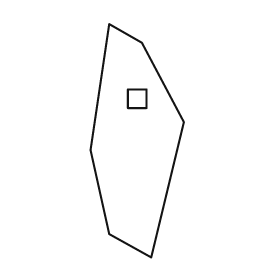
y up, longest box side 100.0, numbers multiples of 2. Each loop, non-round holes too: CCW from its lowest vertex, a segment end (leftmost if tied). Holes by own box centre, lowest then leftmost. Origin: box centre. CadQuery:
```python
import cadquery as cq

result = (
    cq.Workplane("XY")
    .moveTo(6.0, -50.0)
    .lineTo(20.0, 8.0)
    .lineTo(2.0, 42.0)
    .lineTo(-12.0, 50.0)
    .lineTo(-20.0, -4.0)
    .lineTo(-12.0, -40.0)
    .close()
    .moveTo(-4.0, 14.0)
    .lineTo(4.0, 14.0)
    .lineTo(4.0, 22.0)
    .lineTo(-4.0, 22.0)
    .close()
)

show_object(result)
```